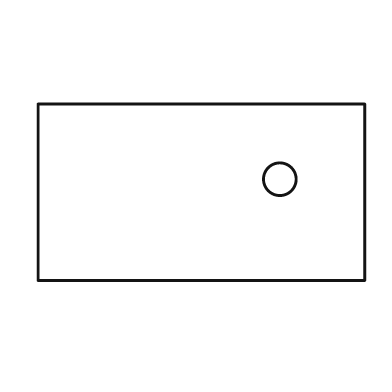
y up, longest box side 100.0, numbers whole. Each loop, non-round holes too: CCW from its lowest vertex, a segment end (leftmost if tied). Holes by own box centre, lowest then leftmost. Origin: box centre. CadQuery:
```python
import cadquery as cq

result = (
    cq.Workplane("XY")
    .moveTo(-50.0, -27.0)
    .lineTo(50.0, -27.0)
    .lineTo(50.0, 27.0)
    .lineTo(-50.0, 27.0)
    .close()
    .moveTo(24.0, 4.0)
    .circle(5.0)
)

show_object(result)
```